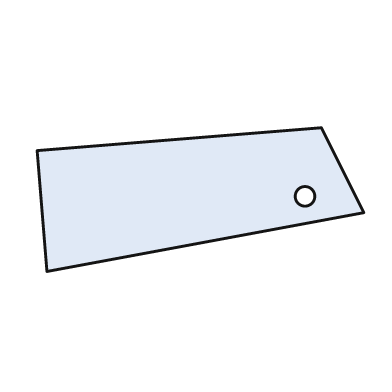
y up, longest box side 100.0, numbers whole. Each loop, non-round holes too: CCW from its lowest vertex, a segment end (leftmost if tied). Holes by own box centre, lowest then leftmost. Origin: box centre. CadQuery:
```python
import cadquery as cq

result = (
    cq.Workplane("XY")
    .moveTo(-47.0, -22.0)
    .lineTo(50.0, -4.0)
    .lineTo(37.0, 22.0)
    .lineTo(-50.0, 15.0)
    .close()
    .moveTo(32.0, 1.0)
    .circle(3.0)
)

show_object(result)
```